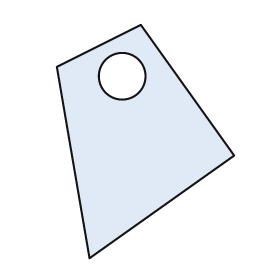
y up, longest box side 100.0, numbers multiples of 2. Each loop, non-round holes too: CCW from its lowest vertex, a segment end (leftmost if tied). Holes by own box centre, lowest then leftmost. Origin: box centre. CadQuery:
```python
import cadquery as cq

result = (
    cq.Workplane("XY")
    .moveTo(-24.0, -50.0)
    .lineTo(38.0, -6.0)
    .lineTo(-2.0, 50.0)
    .lineTo(-38.0, 32.0)
    .close()
    .moveTo(-10.0, 28.0)
    .circle(10.0)
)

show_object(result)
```